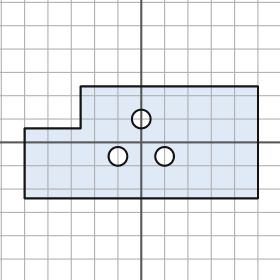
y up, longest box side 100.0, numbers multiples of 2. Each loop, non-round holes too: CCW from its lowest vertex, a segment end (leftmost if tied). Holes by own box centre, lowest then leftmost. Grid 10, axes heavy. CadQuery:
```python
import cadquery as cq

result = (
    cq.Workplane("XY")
    .moveTo(-50.0, -24.0)
    .lineTo(50.0, -24.0)
    .lineTo(50.0, 24.0)
    .lineTo(-26.0, 24.0)
    .lineTo(-26.0, 6.0)
    .lineTo(-50.0, 6.0)
    .close()
    .moveTo(-10.0, -6.0)
    .circle(4.0)
    .moveTo(10.0, -6.0)
    .circle(4.0)
    .moveTo(0.0, 10.0)
    .circle(4.0)
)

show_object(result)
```